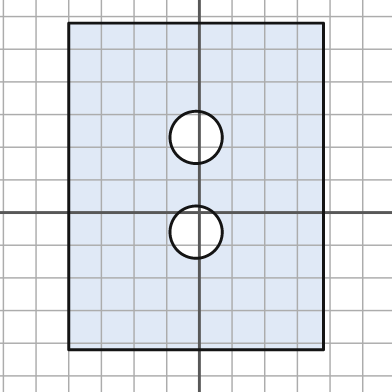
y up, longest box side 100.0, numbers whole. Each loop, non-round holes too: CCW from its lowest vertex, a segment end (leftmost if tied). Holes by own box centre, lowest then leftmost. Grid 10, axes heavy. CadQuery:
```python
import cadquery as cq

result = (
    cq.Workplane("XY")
    .moveTo(-40.0, -42.0)
    .lineTo(38.0, -42.0)
    .lineTo(38.0, 58.0)
    .lineTo(-40.0, 58.0)
    .close()
    .moveTo(-1.0, -6.0)
    .circle(8.0)
    .moveTo(-1.0, 23.0)
    .circle(8.0)
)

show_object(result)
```